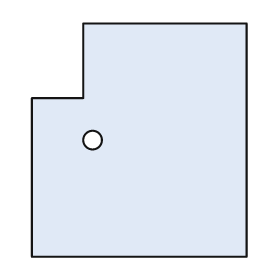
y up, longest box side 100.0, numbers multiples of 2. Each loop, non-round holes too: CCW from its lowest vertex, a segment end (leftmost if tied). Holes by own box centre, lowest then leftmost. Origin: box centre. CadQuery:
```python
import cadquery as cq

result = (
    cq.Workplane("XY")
    .moveTo(-46.0, -50.0)
    .lineTo(46.0, -50.0)
    .lineTo(46.0, 50.0)
    .lineTo(-24.0, 50.0)
    .lineTo(-24.0, 18.0)
    .lineTo(-46.0, 18.0)
    .close()
    .moveTo(-20.0, 0.0)
    .circle(4.0)
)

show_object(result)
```